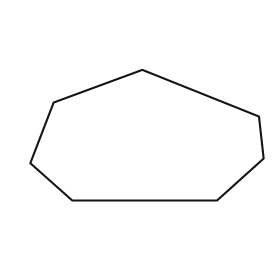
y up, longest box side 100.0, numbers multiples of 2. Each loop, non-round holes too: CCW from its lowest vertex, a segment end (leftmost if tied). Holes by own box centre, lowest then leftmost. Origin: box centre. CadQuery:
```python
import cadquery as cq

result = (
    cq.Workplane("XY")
    .moveTo(-32.0, -28.0)
    .lineTo(30.0, -28.0)
    .lineTo(50.0, -10.0)
    .lineTo(48.0, 8.0)
    .lineTo(-2.0, 28.0)
    .lineTo(-40.0, 14.0)
    .lineTo(-50.0, -12.0)
    .close()
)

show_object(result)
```